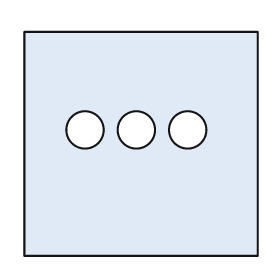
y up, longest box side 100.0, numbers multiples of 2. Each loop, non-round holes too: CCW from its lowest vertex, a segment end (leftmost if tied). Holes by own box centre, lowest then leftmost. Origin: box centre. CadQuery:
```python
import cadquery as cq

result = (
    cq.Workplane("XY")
    .moveTo(-50.0, -48.0)
    .lineTo(50.0, -48.0)
    .lineTo(50.0, 48.0)
    .lineTo(-50.0, 48.0)
    .close()
    .moveTo(-24.0, 6.0)
    .circle(8.0)
    .moveTo(-2.0, 6.0)
    .circle(8.0)
    .moveTo(20.0, 6.0)
    .circle(8.0)
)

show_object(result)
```